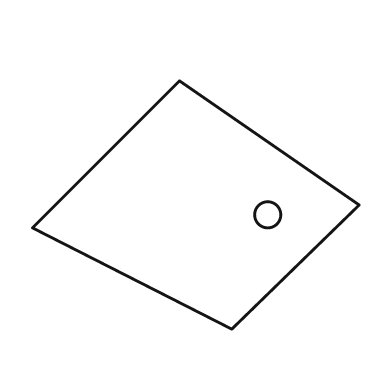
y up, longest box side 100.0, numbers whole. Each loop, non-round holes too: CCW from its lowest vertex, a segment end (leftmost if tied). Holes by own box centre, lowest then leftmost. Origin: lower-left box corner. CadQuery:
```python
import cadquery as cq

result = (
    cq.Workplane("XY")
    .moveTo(61.0, 0.0)
    .lineTo(100.0, 38.0)
    .lineTo(45.0, 76.0)
    .lineTo(0.0, 31.0)
    .close()
    .moveTo(72.0, 35.0)
    .circle(4.0)
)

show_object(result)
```